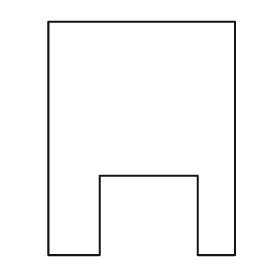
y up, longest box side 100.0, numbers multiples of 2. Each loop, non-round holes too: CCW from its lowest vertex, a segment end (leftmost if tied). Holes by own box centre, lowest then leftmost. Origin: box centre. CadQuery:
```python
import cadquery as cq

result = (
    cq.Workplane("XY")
    .moveTo(-40.0, -50.0)
    .lineTo(-18.0, -50.0)
    .lineTo(-18.0, -16.0)
    .lineTo(24.0, -16.0)
    .lineTo(24.0, -50.0)
    .lineTo(40.0, -50.0)
    .lineTo(40.0, 50.0)
    .lineTo(-40.0, 50.0)
    .close()
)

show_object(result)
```